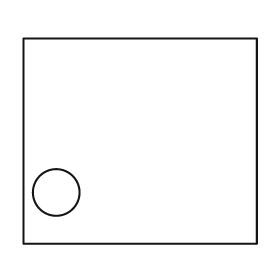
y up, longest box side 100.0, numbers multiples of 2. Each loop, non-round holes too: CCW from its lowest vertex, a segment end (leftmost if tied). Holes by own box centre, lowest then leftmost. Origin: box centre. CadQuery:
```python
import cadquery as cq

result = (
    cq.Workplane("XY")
    .moveTo(-50.0, -44.0)
    .lineTo(50.0, -44.0)
    .lineTo(50.0, 44.0)
    .lineTo(-50.0, 44.0)
    .close()
    .moveTo(-36.0, -22.0)
    .circle(10.0)
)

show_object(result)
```